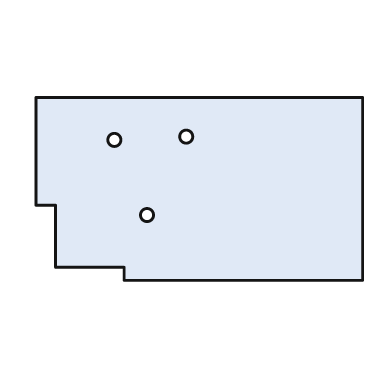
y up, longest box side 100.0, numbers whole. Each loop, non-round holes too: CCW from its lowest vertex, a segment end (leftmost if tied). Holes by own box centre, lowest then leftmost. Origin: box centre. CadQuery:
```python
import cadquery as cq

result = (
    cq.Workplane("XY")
    .moveTo(-23.0, -28.0)
    .lineTo(50.0, -28.0)
    .lineTo(50.0, 28.0)
    .lineTo(-50.0, 28.0)
    .lineTo(-50.0, -5.0)
    .lineTo(-44.0, -5.0)
    .lineTo(-44.0, -24.0)
    .lineTo(-23.0, -24.0)
    .close()
    .moveTo(-16.0, -8.0)
    .circle(2.0)
    .moveTo(-26.0, 15.0)
    .circle(2.0)
    .moveTo(-4.0, 16.0)
    .circle(2.0)
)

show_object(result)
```